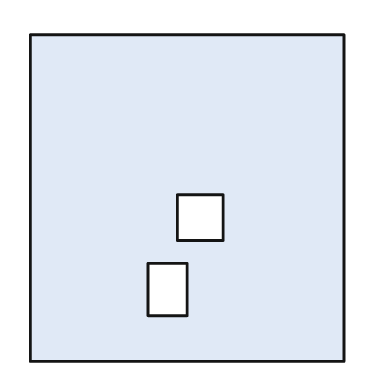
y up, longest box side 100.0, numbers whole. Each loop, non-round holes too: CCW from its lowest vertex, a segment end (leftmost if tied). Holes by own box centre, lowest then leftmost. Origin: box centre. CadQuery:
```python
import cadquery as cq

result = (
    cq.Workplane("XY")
    .moveTo(-48.0, -50.0)
    .lineTo(48.0, -50.0)
    .lineTo(48.0, 50.0)
    .lineTo(-48.0, 50.0)
    .close()
    .moveTo(-12.0, -36.0)
    .lineTo(0.0, -36.0)
    .lineTo(0.0, -20.0)
    .lineTo(-12.0, -20.0)
    .close()
    .moveTo(-3.0, -13.0)
    .lineTo(11.0, -13.0)
    .lineTo(11.0, 1.0)
    .lineTo(-3.0, 1.0)
    .close()
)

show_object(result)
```